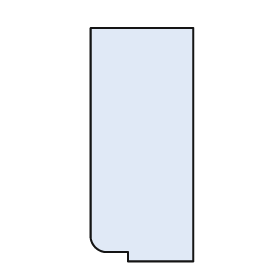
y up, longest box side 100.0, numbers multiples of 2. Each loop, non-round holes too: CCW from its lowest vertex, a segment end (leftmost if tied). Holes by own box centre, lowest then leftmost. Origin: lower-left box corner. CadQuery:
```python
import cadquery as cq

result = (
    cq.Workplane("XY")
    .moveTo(16.0, 0.0)
    .lineTo(44.0, 0.0)
    .lineTo(44.0, 100.0)
    .lineTo(0.0, 100.0)
    .lineTo(0.0, 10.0)
    .threePointArc((2.0, 6.0), (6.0, 4.0))
    .lineTo(16.0, 4.0)
    .close()
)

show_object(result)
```